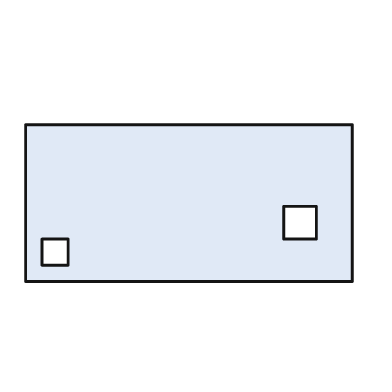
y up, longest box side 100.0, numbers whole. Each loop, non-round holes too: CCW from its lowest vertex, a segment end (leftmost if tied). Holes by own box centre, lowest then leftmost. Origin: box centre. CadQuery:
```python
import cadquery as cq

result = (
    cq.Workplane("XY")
    .moveTo(-50.0, -24.0)
    .lineTo(50.0, -24.0)
    .lineTo(50.0, 24.0)
    .lineTo(-50.0, 24.0)
    .close()
    .moveTo(-45.0, -19.0)
    .lineTo(-37.0, -19.0)
    .lineTo(-37.0, -11.0)
    .lineTo(-45.0, -11.0)
    .close()
    .moveTo(29.0, -11.0)
    .lineTo(39.0, -11.0)
    .lineTo(39.0, -1.0)
    .lineTo(29.0, -1.0)
    .close()
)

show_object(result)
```